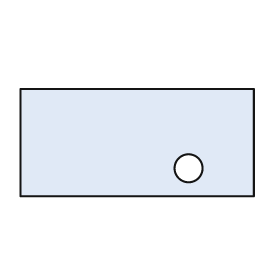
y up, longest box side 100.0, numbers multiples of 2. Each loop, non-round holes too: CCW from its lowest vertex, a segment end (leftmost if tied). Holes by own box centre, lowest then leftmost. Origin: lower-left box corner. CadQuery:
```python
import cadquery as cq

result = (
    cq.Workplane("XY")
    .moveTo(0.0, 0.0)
    .lineTo(100.0, 0.0)
    .lineTo(100.0, 46.0)
    .lineTo(0.0, 46.0)
    .close()
    .moveTo(72.0, 12.0)
    .circle(6.0)
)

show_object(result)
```